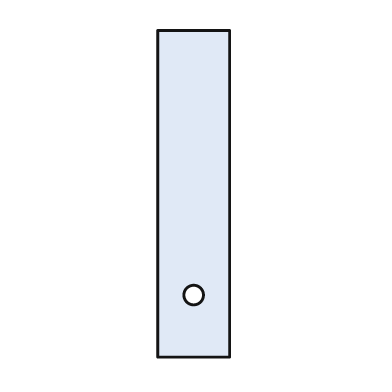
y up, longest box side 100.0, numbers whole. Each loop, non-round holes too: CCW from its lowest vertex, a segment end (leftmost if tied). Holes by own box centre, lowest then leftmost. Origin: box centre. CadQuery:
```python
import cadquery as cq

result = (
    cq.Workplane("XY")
    .moveTo(-11.0, -50.0)
    .lineTo(11.0, -50.0)
    .lineTo(11.0, 50.0)
    .lineTo(-11.0, 50.0)
    .close()
    .moveTo(0.0, -31.0)
    .circle(3.0)
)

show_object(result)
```